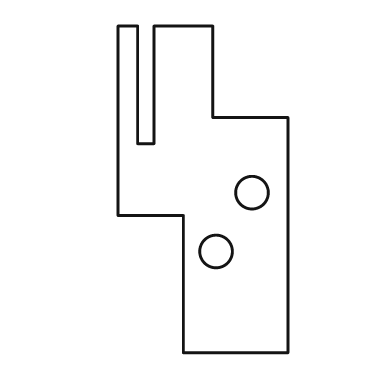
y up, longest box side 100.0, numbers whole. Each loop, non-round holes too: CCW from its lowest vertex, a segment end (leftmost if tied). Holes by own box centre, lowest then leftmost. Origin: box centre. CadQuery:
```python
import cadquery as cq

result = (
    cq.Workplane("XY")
    .moveTo(-6.0, -50.0)
    .lineTo(26.0, -50.0)
    .lineTo(26.0, 22.0)
    .lineTo(3.0, 22.0)
    .lineTo(3.0, 50.0)
    .lineTo(-15.0, 50.0)
    .lineTo(-15.0, 14.0)
    .lineTo(-20.0, 14.0)
    .lineTo(-20.0, 50.0)
    .lineTo(-26.0, 50.0)
    .lineTo(-26.0, -8.0)
    .lineTo(-6.0, -8.0)
    .close()
    .moveTo(4.0, -19.0)
    .circle(5.0)
    .moveTo(15.0, -1.0)
    .circle(5.0)
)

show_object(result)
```